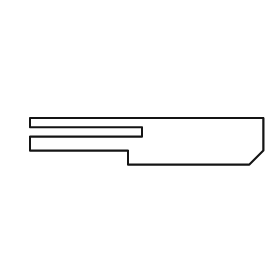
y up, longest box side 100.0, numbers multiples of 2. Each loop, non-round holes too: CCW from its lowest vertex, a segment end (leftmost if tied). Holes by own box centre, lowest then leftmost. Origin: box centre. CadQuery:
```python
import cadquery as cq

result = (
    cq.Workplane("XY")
    .moveTo(-8.0, -10.0)
    .lineTo(44.0, -10.0)
    .lineTo(50.0, -4.0)
    .lineTo(50.0, 10.0)
    .lineTo(-50.0, 10.0)
    .lineTo(-50.0, 6.0)
    .lineTo(-2.0, 6.0)
    .lineTo(-2.0, 2.0)
    .lineTo(-50.0, 2.0)
    .lineTo(-50.0, -4.0)
    .lineTo(-8.0, -4.0)
    .close()
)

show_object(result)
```